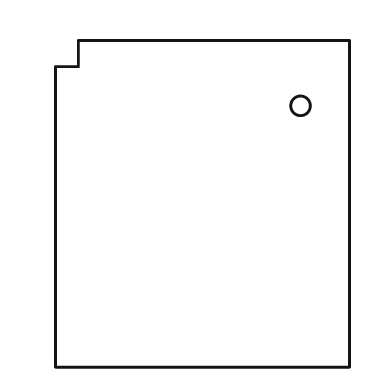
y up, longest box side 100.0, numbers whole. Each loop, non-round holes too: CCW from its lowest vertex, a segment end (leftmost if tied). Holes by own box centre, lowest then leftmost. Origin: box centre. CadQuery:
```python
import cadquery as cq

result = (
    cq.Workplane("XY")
    .moveTo(-45.0, -50.0)
    .lineTo(45.0, -50.0)
    .lineTo(45.0, 50.0)
    .lineTo(-38.0, 50.0)
    .lineTo(-38.0, 42.0)
    .lineTo(-45.0, 42.0)
    .close()
    .moveTo(30.0, 30.0)
    .circle(3.0)
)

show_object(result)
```